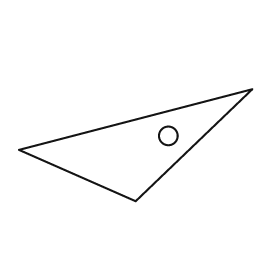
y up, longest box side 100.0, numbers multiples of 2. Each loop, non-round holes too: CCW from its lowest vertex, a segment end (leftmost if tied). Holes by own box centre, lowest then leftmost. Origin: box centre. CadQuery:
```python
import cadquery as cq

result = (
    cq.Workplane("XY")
    .moveTo(0.0, -24.0)
    .lineTo(50.0, 24.0)
    .lineTo(-50.0, -2.0)
    .close()
    .moveTo(14.0, 4.0)
    .circle(4.0)
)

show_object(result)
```